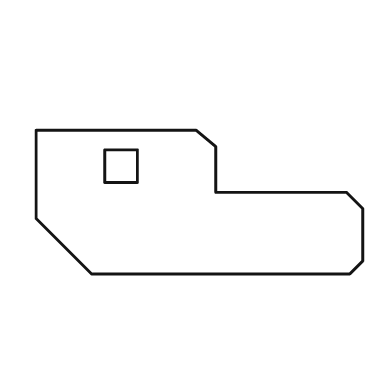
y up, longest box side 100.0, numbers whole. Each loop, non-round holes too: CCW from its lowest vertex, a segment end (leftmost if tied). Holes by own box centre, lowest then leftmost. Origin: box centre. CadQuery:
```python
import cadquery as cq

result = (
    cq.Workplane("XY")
    .moveTo(-33.0, -22.0)
    .lineTo(46.0, -22.0)
    .lineTo(50.0, -18.0)
    .lineTo(50.0, -2.0)
    .lineTo(45.0, 3.0)
    .lineTo(5.0, 3.0)
    .lineTo(5.0, 17.0)
    .lineTo(-1.0, 22.0)
    .lineTo(-50.0, 22.0)
    .lineTo(-50.0, -5.0)
    .close()
    .moveTo(-29.0, 6.0)
    .lineTo(-19.0, 6.0)
    .lineTo(-19.0, 16.0)
    .lineTo(-29.0, 16.0)
    .close()
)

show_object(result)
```